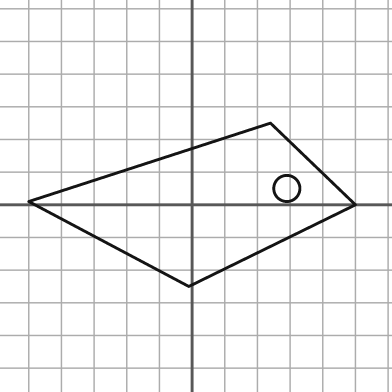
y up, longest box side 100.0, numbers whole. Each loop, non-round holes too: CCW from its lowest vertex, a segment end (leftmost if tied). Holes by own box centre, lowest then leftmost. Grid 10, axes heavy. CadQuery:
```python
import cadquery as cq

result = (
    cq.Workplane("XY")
    .moveTo(-1.0, -25.0)
    .lineTo(50.0, 0.0)
    .lineTo(24.0, 25.0)
    .lineTo(-50.0, 1.0)
    .close()
    .moveTo(29.0, 5.0)
    .circle(4.0)
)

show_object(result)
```